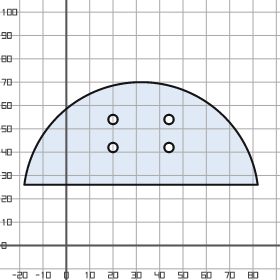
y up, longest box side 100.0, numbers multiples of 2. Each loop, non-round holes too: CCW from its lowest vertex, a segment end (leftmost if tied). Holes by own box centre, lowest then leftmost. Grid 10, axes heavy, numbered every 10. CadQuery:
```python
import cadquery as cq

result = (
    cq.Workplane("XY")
    .moveTo(-18.0, 26.0)
    .lineTo(82.0, 26.0)
    .threePointArc((32.0, 70.0), (-18.0, 26.0))
    .close()
    .moveTo(20.0, 42.0)
    .circle(2.0)
    .moveTo(44.0, 42.0)
    .circle(2.0)
    .moveTo(20.0, 54.0)
    .circle(2.0)
    .moveTo(44.0, 54.0)
    .circle(2.0)
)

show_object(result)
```